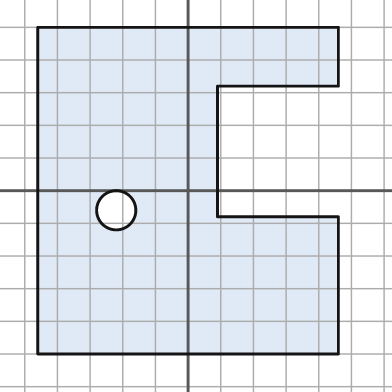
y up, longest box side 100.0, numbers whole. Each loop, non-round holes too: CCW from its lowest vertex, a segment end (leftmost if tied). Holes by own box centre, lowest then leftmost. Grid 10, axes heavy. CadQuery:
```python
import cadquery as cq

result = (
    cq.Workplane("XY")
    .moveTo(-46.0, -50.0)
    .lineTo(46.0, -50.0)
    .lineTo(46.0, -8.0)
    .lineTo(9.0, -8.0)
    .lineTo(9.0, 32.0)
    .lineTo(46.0, 32.0)
    .lineTo(46.0, 50.0)
    .lineTo(-46.0, 50.0)
    .close()
    .moveTo(-22.0, -6.0)
    .circle(6.0)
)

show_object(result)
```